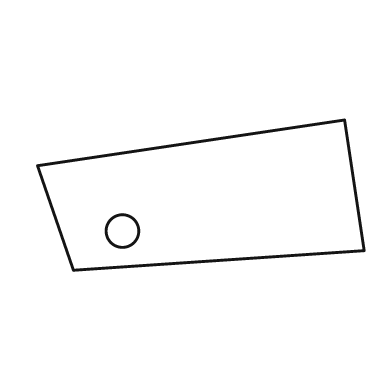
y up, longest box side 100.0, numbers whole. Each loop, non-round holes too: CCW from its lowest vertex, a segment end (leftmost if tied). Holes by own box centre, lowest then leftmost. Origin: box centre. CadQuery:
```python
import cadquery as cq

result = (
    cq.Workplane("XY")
    .moveTo(-39.0, -23.0)
    .lineTo(50.0, -17.0)
    .lineTo(44.0, 23.0)
    .lineTo(-50.0, 9.0)
    .close()
    .moveTo(-24.0, -11.0)
    .circle(5.0)
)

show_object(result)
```